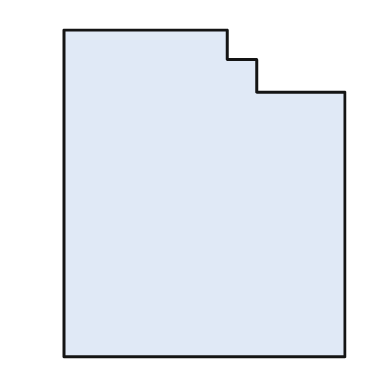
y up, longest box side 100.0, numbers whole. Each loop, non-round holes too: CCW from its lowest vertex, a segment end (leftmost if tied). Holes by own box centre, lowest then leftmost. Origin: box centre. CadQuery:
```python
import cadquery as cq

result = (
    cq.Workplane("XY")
    .moveTo(-43.0, -50.0)
    .lineTo(43.0, -50.0)
    .lineTo(43.0, 31.0)
    .lineTo(16.0, 31.0)
    .lineTo(16.0, 41.0)
    .lineTo(7.0, 41.0)
    .lineTo(7.0, 50.0)
    .lineTo(-43.0, 50.0)
    .close()
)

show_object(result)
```